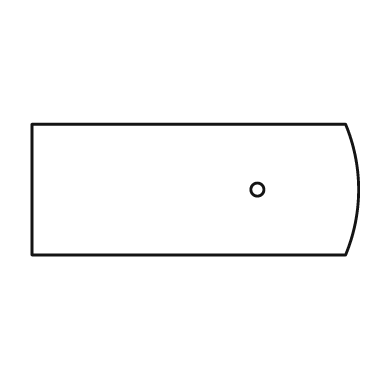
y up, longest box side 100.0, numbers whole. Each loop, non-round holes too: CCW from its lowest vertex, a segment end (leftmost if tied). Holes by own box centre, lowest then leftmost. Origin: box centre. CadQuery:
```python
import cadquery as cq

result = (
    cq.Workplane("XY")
    .moveTo(-50.0, -20.0)
    .lineTo(46.0, -20.0)
    .threePointArc((50.0, 0.0), (46.0, 20.0))
    .lineTo(-50.0, 20.0)
    .close()
    .moveTo(19.0, 0.0)
    .circle(2.0)
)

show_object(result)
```